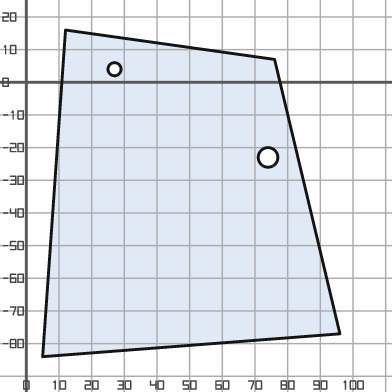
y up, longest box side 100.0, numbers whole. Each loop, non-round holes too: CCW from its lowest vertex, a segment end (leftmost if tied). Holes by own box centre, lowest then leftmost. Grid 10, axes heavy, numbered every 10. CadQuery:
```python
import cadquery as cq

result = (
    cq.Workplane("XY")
    .moveTo(5.0, -84.0)
    .lineTo(96.0, -77.0)
    .lineTo(76.0, 7.0)
    .lineTo(12.0, 16.0)
    .close()
    .moveTo(74.0, -23.0)
    .circle(3.0)
    .moveTo(27.0, 4.0)
    .circle(2.0)
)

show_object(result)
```